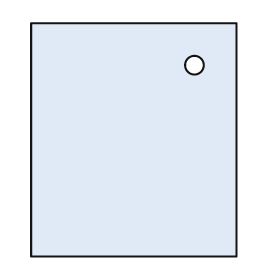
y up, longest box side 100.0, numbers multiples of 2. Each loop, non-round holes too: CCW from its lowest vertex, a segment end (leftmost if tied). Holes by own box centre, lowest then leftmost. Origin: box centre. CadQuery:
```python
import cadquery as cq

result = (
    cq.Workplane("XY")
    .moveTo(-44.0, -50.0)
    .lineTo(44.0, -50.0)
    .lineTo(44.0, 50.0)
    .lineTo(-44.0, 50.0)
    .close()
    .moveTo(26.0, 32.0)
    .circle(4.0)
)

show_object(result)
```